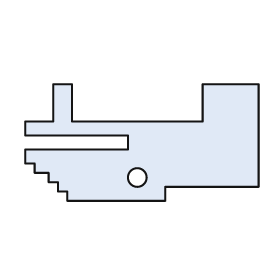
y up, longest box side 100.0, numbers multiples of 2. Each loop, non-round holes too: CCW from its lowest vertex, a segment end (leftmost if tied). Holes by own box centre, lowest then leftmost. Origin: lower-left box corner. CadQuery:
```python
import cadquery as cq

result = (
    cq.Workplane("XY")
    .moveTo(18.0, 0.0)
    .lineTo(60.0, 0.0)
    .lineTo(60.0, 6.0)
    .lineTo(100.0, 6.0)
    .lineTo(100.0, 50.0)
    .lineTo(76.0, 50.0)
    .lineTo(76.0, 34.0)
    .lineTo(20.0, 34.0)
    .lineTo(20.0, 50.0)
    .lineTo(12.0, 50.0)
    .lineTo(12.0, 34.0)
    .lineTo(0.0, 34.0)
    .lineTo(0.0, 28.0)
    .lineTo(44.0, 28.0)
    .lineTo(44.0, 22.0)
    .lineTo(0.0, 22.0)
    .lineTo(0.0, 16.0)
    .lineTo(4.0, 16.0)
    .lineTo(4.0, 12.0)
    .lineTo(10.0, 12.0)
    .lineTo(10.0, 8.0)
    .lineTo(14.0, 8.0)
    .lineTo(14.0, 4.0)
    .lineTo(18.0, 4.0)
    .close()
    .moveTo(48.0, 10.0)
    .circle(4.0)
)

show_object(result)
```